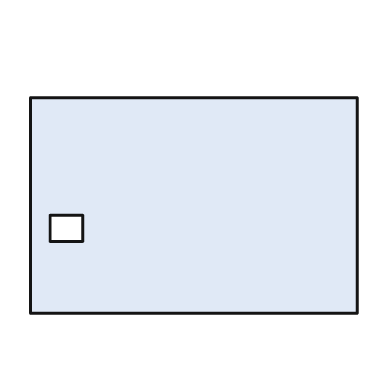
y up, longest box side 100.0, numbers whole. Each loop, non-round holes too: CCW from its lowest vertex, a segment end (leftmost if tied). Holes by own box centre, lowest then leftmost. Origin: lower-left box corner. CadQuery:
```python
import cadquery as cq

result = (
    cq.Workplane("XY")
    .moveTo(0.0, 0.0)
    .lineTo(100.0, 0.0)
    .lineTo(100.0, 66.0)
    .lineTo(0.0, 66.0)
    .close()
    .moveTo(6.0, 22.0)
    .lineTo(16.0, 22.0)
    .lineTo(16.0, 30.0)
    .lineTo(6.0, 30.0)
    .close()
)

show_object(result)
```